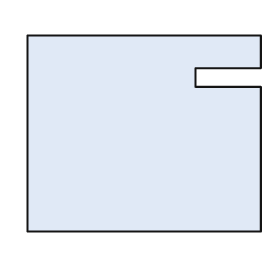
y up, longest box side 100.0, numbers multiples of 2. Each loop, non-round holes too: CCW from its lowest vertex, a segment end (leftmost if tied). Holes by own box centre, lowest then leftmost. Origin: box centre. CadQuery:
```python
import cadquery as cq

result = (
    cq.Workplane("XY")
    .moveTo(-50.0, -42.0)
    .lineTo(50.0, -42.0)
    .lineTo(50.0, 20.0)
    .lineTo(22.0, 20.0)
    .lineTo(22.0, 28.0)
    .lineTo(50.0, 28.0)
    .lineTo(50.0, 42.0)
    .lineTo(-50.0, 42.0)
    .close()
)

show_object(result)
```